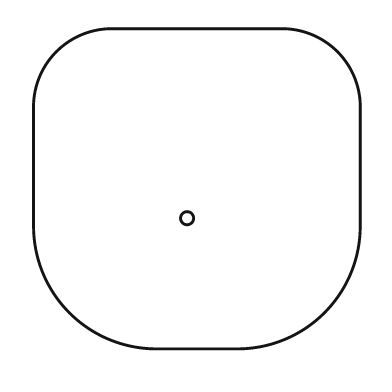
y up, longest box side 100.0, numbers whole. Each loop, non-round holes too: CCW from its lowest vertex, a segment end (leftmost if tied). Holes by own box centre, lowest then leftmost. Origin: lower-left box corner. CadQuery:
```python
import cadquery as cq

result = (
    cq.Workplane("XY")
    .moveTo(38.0, 0.0)
    .lineTo(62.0, 0.0)
    .threePointArc((89.0, 11.0), (100.0, 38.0))
    .lineTo(100.0, 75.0)
    .threePointArc((93.0, 91.0), (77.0, 98.0))
    .lineTo(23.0, 98.0)
    .threePointArc((7.0, 91.0), (0.0, 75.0))
    .lineTo(0.0, 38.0)
    .threePointArc((11.0, 11.0), (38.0, 0.0))
    .close()
    .moveTo(47.0, 40.0)
    .circle(2.0)
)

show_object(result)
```